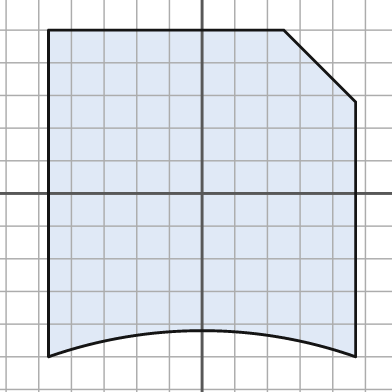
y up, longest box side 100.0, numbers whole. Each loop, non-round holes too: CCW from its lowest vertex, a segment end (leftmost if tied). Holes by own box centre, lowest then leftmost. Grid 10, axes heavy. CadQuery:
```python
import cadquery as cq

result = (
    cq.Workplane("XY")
    .moveTo(-47.0, -50.0)
    .threePointArc((0.0, -42.0), (47.0, -50.0))
    .lineTo(47.0, 28.0)
    .lineTo(25.0, 50.0)
    .lineTo(-47.0, 50.0)
    .close()
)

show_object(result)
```